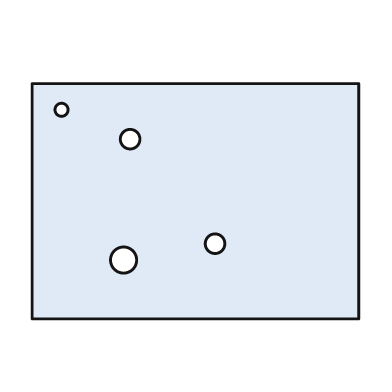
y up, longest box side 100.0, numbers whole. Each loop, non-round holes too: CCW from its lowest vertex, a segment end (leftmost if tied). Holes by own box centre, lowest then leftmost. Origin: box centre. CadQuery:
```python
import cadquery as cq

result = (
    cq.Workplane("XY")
    .moveTo(-50.0, -36.0)
    .lineTo(50.0, -36.0)
    .lineTo(50.0, 36.0)
    .lineTo(-50.0, 36.0)
    .close()
    .moveTo(-22.0, -18.0)
    .circle(4.0)
    .moveTo(6.0, -13.0)
    .circle(3.0)
    .moveTo(-20.0, 19.0)
    .circle(3.0)
    .moveTo(-41.0, 28.0)
    .circle(2.0)
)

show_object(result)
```